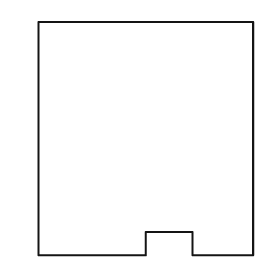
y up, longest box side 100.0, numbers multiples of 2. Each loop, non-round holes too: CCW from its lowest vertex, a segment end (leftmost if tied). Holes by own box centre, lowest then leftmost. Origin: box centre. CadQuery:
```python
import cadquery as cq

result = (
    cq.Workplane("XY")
    .moveTo(-46.0, -50.0)
    .lineTo(0.0, -50.0)
    .lineTo(0.0, -40.0)
    .lineTo(20.0, -40.0)
    .lineTo(20.0, -50.0)
    .lineTo(46.0, -50.0)
    .lineTo(46.0, 50.0)
    .lineTo(-46.0, 50.0)
    .close()
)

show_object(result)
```